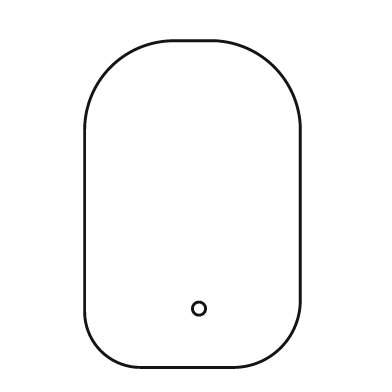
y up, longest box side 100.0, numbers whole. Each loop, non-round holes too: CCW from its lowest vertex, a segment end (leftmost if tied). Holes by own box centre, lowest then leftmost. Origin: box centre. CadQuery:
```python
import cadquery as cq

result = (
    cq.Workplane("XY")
    .moveTo(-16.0, -50.0)
    .lineTo(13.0, -50.0)
    .threePointArc((27.0, -44.0), (33.0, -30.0))
    .lineTo(33.0, 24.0)
    .threePointArc((25.0, 42.0), (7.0, 50.0))
    .lineTo(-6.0, 50.0)
    .threePointArc((-25.0, 42.0), (-33.0, 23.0))
    .lineTo(-33.0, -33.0)
    .threePointArc((-28.0, -45.0), (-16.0, -50.0))
    .close()
    .moveTo(2.0, -32.0)
    .circle(2.0)
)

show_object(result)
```